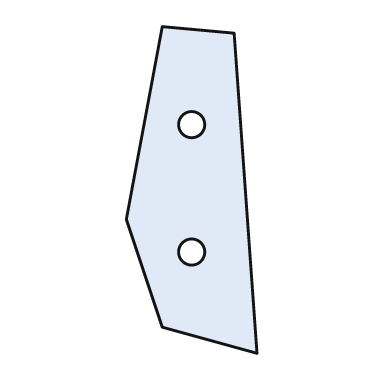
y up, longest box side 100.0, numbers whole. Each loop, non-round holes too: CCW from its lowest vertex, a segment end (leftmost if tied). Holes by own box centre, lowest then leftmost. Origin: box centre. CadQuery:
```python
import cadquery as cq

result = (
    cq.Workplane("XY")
    .moveTo(20.0, -50.0)
    .lineTo(13.0, 48.0)
    .lineTo(-9.0, 50.0)
    .lineTo(-20.0, -9.0)
    .lineTo(-9.0, -42.0)
    .close()
    .moveTo(0.0, -19.0)
    .circle(4.0)
    .moveTo(0.0, 20.0)
    .circle(4.0)
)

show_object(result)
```